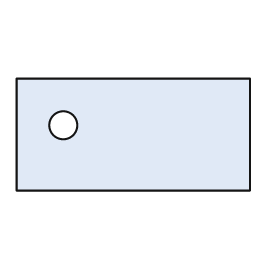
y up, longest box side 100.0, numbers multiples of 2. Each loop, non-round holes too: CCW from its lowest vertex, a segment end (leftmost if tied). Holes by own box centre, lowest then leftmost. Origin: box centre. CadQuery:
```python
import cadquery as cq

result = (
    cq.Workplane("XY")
    .moveTo(-50.0, -24.0)
    .lineTo(50.0, -24.0)
    .lineTo(50.0, 24.0)
    .lineTo(-50.0, 24.0)
    .close()
    .moveTo(-30.0, 4.0)
    .circle(6.0)
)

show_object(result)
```